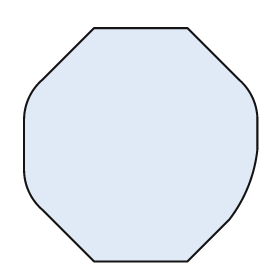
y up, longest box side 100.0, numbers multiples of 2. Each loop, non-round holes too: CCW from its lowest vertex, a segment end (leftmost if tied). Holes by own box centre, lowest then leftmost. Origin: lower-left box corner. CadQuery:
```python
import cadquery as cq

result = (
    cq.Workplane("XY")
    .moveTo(30.0, 0.0)
    .lineTo(70.0, 0.0)
    .lineTo(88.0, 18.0)
    .threePointArc((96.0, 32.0), (100.0, 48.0))
    .lineTo(100.0, 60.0)
    .threePointArc((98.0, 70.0), (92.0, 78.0))
    .lineTo(70.0, 100.0)
    .lineTo(30.0, 100.0)
    .lineTo(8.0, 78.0)
    .threePointArc((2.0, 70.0), (0.0, 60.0))
    .lineTo(0.0, 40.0)
    .threePointArc((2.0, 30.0), (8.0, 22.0))
    .close()
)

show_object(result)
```